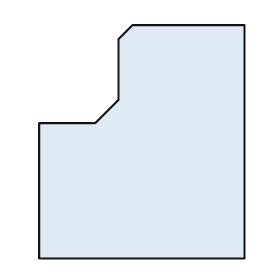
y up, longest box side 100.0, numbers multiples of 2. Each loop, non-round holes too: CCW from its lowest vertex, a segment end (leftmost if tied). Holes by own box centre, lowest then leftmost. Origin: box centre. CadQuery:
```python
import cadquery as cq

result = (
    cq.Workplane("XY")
    .moveTo(-44.0, -50.0)
    .lineTo(44.0, -50.0)
    .lineTo(44.0, 50.0)
    .lineTo(-4.0, 50.0)
    .lineTo(-10.0, 44.0)
    .lineTo(-10.0, 18.0)
    .lineTo(-20.0, 8.0)
    .lineTo(-44.0, 8.0)
    .close()
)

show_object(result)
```